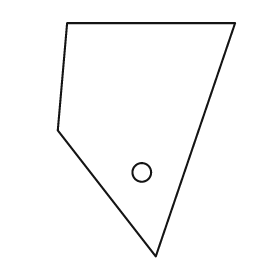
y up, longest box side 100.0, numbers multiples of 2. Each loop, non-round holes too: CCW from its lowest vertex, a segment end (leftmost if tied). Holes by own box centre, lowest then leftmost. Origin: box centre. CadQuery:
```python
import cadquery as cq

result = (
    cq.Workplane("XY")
    .moveTo(4.0, -50.0)
    .lineTo(38.0, 50.0)
    .lineTo(-34.0, 50.0)
    .lineTo(-38.0, 4.0)
    .close()
    .moveTo(-2.0, -14.0)
    .circle(4.0)
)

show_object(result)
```